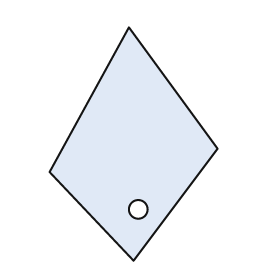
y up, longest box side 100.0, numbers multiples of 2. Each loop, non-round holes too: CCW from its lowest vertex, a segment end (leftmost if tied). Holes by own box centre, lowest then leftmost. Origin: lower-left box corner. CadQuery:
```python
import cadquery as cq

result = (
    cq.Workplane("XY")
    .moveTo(36.0, 0.0)
    .lineTo(72.0, 48.0)
    .lineTo(34.0, 100.0)
    .lineTo(0.0, 38.0)
    .close()
    .moveTo(38.0, 22.0)
    .circle(4.0)
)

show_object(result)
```